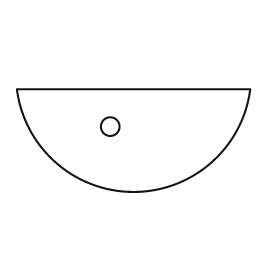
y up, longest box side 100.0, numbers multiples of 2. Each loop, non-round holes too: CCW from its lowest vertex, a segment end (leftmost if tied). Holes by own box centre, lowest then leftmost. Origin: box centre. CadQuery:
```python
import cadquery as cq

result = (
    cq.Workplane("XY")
    .moveTo(-50.0, 22.0)
    .threePointArc((0.0, -22.0), (50.0, 22.0))
    .close()
    .moveTo(-10.0, 6.0)
    .circle(4.0)
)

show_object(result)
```